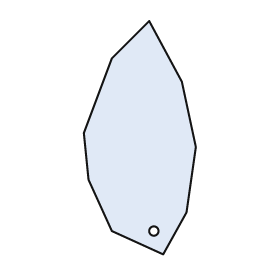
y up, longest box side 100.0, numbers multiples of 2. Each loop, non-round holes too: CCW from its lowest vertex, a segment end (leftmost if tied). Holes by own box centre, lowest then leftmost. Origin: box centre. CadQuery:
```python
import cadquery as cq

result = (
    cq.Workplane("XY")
    .moveTo(10.0, -50.0)
    .lineTo(20.0, -32.0)
    .lineTo(24.0, -4.0)
    .lineTo(18.0, 24.0)
    .lineTo(4.0, 50.0)
    .lineTo(-12.0, 34.0)
    .lineTo(-24.0, 2.0)
    .lineTo(-22.0, -18.0)
    .lineTo(-12.0, -40.0)
    .close()
    .moveTo(6.0, -40.0)
    .circle(2.0)
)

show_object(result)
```